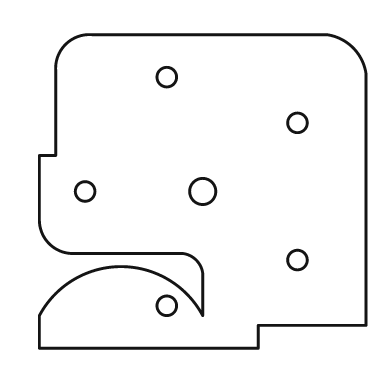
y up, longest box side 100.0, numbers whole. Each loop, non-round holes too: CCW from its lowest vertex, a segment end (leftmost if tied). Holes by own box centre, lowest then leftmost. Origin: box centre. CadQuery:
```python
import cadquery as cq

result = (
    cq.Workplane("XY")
    .moveTo(-50.0, -48.0)
    .lineTo(17.0, -48.0)
    .lineTo(17.0, -41.0)
    .lineTo(50.0, -41.0)
    .lineTo(50.0, 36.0)
    .threePointArc((46.0, 44.0), (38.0, 48.0))
    .lineTo(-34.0, 48.0)
    .threePointArc((-42.0, 45.0), (-45.0, 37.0))
    .lineTo(-45.0, 11.0)
    .lineTo(-50.0, 11.0)
    .lineTo(-50.0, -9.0)
    .threePointArc((-47.0, -16.0), (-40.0, -19.0))
    .lineTo(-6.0, -19.0)
    .threePointArc((-2.0, -21.0), (0.0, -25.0))
    .lineTo(0.0, -38.0)
    .threePointArc((-25.0, -23.0), (-50.0, -38.0))
    .close()
    .moveTo(-11.0, -35.0)
    .circle(3.0)
    .moveTo(29.0, -21.0)
    .circle(3.0)
    .moveTo(-36.0, 0.0)
    .circle(3.0)
    .moveTo(0.0, 0.0)
    .circle(4.0)
    .moveTo(29.0, 21.0)
    .circle(3.0)
    .moveTo(-11.0, 35.0)
    .circle(3.0)
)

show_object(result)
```